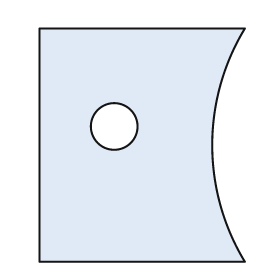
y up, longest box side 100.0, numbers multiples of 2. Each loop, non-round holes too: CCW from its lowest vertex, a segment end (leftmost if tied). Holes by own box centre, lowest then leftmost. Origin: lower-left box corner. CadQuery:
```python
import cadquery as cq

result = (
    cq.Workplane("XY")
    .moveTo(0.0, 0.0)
    .lineTo(88.0, 0.0)
    .threePointArc((74.0, 50.0), (88.0, 100.0))
    .lineTo(0.0, 100.0)
    .close()
    .moveTo(32.0, 58.0)
    .circle(10.0)
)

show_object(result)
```